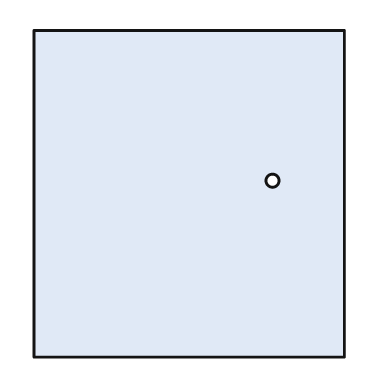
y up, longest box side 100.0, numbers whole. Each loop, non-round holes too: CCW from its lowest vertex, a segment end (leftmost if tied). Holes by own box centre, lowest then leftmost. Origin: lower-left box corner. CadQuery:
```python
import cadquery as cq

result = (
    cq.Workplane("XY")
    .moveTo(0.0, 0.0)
    .lineTo(95.0, 0.0)
    .lineTo(95.0, 100.0)
    .lineTo(0.0, 100.0)
    .close()
    .moveTo(73.0, 54.0)
    .circle(2.0)
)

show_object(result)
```